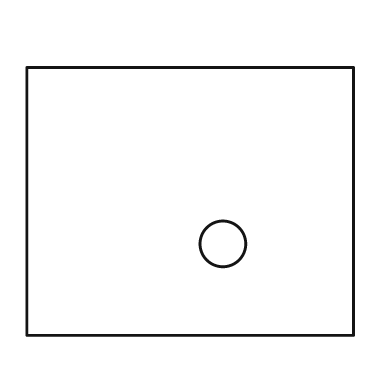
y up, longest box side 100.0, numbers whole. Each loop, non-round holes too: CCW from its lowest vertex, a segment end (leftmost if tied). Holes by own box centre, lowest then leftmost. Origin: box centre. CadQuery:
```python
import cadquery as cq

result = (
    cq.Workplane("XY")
    .moveTo(-50.0, -41.0)
    .lineTo(50.0, -41.0)
    .lineTo(50.0, 41.0)
    .lineTo(-50.0, 41.0)
    .close()
    .moveTo(10.0, -13.0)
    .circle(7.0)
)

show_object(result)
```